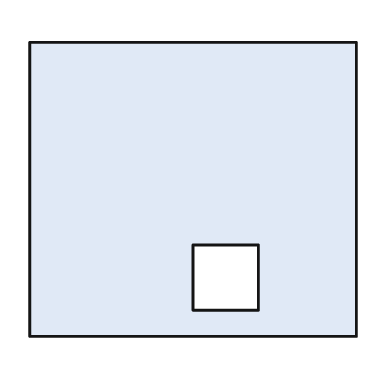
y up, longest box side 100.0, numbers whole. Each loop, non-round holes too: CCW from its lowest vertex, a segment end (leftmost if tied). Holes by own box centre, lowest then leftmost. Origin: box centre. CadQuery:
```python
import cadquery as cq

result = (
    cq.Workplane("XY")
    .moveTo(-50.0, -45.0)
    .lineTo(50.0, -45.0)
    .lineTo(50.0, 45.0)
    .lineTo(-50.0, 45.0)
    .close()
    .moveTo(0.0, -37.0)
    .lineTo(20.0, -37.0)
    .lineTo(20.0, -17.0)
    .lineTo(0.0, -17.0)
    .close()
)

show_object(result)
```